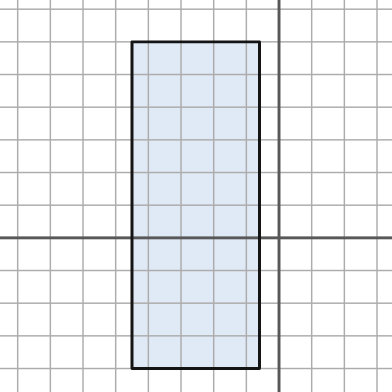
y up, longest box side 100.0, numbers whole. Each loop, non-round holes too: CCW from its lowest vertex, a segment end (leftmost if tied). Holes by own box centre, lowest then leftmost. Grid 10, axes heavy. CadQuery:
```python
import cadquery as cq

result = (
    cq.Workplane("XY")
    .moveTo(-45.0, -40.0)
    .lineTo(-6.0, -40.0)
    .lineTo(-6.0, 60.0)
    .lineTo(-45.0, 60.0)
    .close()
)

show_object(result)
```